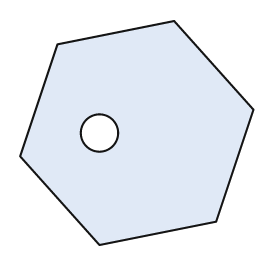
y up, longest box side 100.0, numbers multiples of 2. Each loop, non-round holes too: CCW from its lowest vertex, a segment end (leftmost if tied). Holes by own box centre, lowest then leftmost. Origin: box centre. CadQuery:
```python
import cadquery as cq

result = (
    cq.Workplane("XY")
    .moveTo(-16.0, -48.0)
    .lineTo(34.0, -38.0)
    .lineTo(50.0, 10.0)
    .lineTo(16.0, 48.0)
    .lineTo(-34.0, 38.0)
    .lineTo(-50.0, -10.0)
    .close()
    .moveTo(-16.0, 0.0)
    .circle(8.0)
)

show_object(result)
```